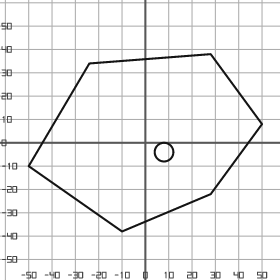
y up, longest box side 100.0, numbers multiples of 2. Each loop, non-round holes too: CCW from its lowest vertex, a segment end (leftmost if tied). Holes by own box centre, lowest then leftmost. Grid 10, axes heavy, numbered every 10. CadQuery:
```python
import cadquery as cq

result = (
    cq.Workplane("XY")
    .moveTo(-10.0, -38.0)
    .lineTo(28.0, -22.0)
    .lineTo(50.0, 8.0)
    .lineTo(28.0, 38.0)
    .lineTo(-24.0, 34.0)
    .lineTo(-50.0, -10.0)
    .close()
    .moveTo(8.0, -4.0)
    .circle(4.0)
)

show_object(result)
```